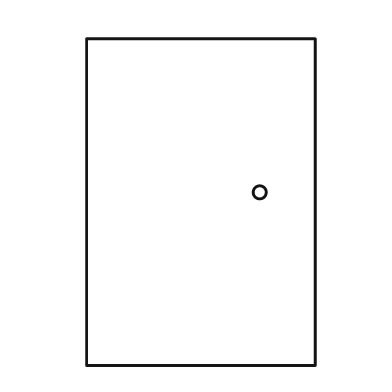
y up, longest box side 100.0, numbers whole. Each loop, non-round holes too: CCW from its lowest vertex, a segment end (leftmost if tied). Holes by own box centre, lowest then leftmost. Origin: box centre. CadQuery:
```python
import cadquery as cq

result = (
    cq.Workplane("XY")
    .moveTo(-35.0, -50.0)
    .lineTo(35.0, -50.0)
    .lineTo(35.0, 50.0)
    .lineTo(-35.0, 50.0)
    .close()
    .moveTo(18.0, 3.0)
    .circle(2.0)
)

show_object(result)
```